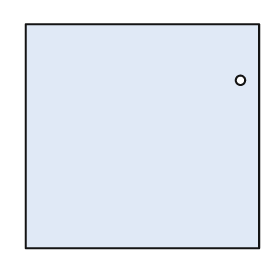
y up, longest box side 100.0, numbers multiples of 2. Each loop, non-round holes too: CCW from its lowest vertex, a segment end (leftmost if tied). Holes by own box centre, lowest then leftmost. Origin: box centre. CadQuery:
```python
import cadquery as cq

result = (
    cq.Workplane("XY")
    .moveTo(-50.0, -48.0)
    .lineTo(50.0, -48.0)
    .lineTo(50.0, 48.0)
    .lineTo(-50.0, 48.0)
    .close()
    .moveTo(42.0, 24.0)
    .circle(2.0)
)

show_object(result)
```